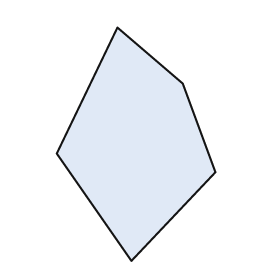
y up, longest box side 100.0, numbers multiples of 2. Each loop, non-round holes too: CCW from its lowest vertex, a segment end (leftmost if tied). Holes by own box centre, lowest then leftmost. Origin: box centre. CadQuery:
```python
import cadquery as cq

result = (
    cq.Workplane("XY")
    .moveTo(-2.0, -50.0)
    .lineTo(34.0, -12.0)
    .lineTo(20.0, 26.0)
    .lineTo(-8.0, 50.0)
    .lineTo(-34.0, -4.0)
    .close()
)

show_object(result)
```